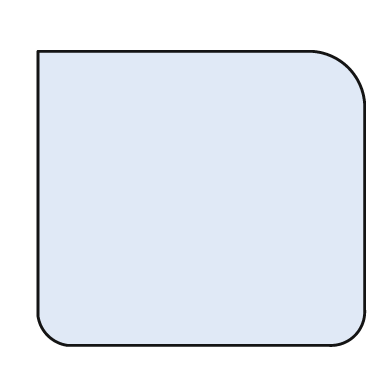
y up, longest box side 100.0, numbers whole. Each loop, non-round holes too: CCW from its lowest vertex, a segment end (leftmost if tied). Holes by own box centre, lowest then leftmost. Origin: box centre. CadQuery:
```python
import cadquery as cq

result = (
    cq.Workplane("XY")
    .moveTo(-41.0, -45.0)
    .lineTo(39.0, -45.0)
    .threePointArc((47.0, -42.0), (50.0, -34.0))
    .lineTo(50.0, 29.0)
    .threePointArc((45.0, 40.0), (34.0, 45.0))
    .lineTo(-50.0, 45.0)
    .lineTo(-50.0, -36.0)
    .threePointArc((-47.0, -42.0), (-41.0, -45.0))
    .close()
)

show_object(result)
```